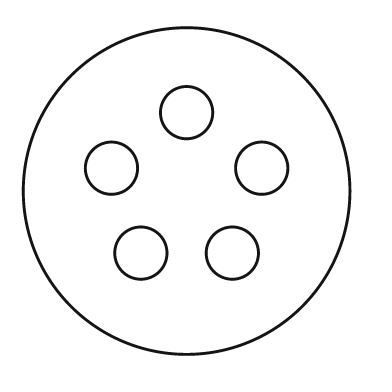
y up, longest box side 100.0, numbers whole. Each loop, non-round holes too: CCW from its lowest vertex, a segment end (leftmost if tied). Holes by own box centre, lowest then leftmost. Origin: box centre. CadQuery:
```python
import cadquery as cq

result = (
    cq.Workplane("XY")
    .moveTo(0.0, 0.0)
    .circle(50.0)
    .moveTo(-14.0, -19.0)
    .circle(8.0)
    .moveTo(14.0, -19.0)
    .circle(8.0)
    .moveTo(-23.0, 7.0)
    .circle(8.0)
    .moveTo(23.0, 7.0)
    .circle(8.0)
    .moveTo(0.0, 24.0)
    .circle(8.0)
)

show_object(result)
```